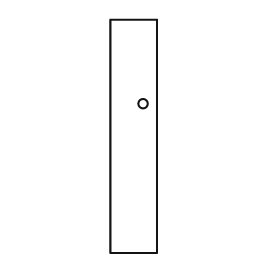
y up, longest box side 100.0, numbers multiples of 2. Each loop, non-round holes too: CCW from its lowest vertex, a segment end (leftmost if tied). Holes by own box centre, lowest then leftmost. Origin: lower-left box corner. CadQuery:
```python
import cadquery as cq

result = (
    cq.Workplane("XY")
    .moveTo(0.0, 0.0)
    .lineTo(20.0, 0.0)
    .lineTo(20.0, 100.0)
    .lineTo(0.0, 100.0)
    .close()
    .moveTo(14.0, 64.0)
    .circle(2.0)
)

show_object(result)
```